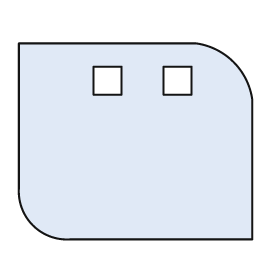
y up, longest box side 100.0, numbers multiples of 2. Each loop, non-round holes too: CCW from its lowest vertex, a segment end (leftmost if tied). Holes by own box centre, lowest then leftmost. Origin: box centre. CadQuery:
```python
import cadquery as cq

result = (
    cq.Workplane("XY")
    .moveTo(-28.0, -42.0)
    .lineTo(50.0, -42.0)
    .lineTo(50.0, 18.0)
    .threePointArc((42.0, 34.0), (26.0, 42.0))
    .lineTo(-50.0, 42.0)
    .lineTo(-50.0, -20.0)
    .threePointArc((-44.0, -36.0), (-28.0, -42.0))
    .close()
    .moveTo(-18.0, 20.0)
    .lineTo(-6.0, 20.0)
    .lineTo(-6.0, 32.0)
    .lineTo(-18.0, 32.0)
    .close()
    .moveTo(12.0, 20.0)
    .lineTo(24.0, 20.0)
    .lineTo(24.0, 32.0)
    .lineTo(12.0, 32.0)
    .close()
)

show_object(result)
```